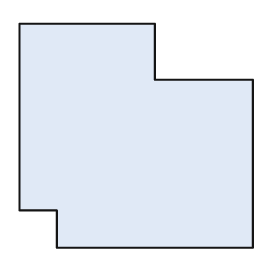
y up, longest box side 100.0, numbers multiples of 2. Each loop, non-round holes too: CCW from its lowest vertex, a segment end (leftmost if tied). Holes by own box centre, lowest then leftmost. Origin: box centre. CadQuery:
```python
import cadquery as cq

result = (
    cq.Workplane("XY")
    .moveTo(-34.0, -48.0)
    .lineTo(50.0, -48.0)
    .lineTo(50.0, 24.0)
    .lineTo(8.0, 24.0)
    .lineTo(8.0, 48.0)
    .lineTo(-50.0, 48.0)
    .lineTo(-50.0, -32.0)
    .lineTo(-34.0, -32.0)
    .close()
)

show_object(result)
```